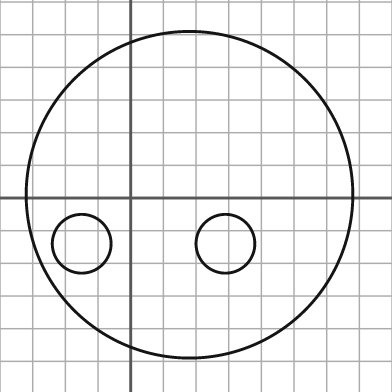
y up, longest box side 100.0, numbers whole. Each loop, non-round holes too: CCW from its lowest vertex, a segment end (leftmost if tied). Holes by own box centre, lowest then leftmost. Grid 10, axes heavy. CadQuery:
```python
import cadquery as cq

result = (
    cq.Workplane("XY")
    .moveTo(18.0, 1.0)
    .circle(50.0)
    .moveTo(-15.0, -14.0)
    .circle(9.0)
    .moveTo(29.0, -14.0)
    .circle(9.0)
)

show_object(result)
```